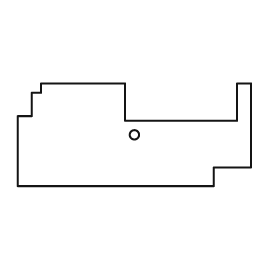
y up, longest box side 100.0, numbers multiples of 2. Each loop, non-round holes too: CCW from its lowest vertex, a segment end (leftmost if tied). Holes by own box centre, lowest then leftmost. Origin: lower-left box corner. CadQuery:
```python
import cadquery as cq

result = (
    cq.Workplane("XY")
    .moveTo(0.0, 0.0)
    .lineTo(84.0, 0.0)
    .lineTo(84.0, 8.0)
    .lineTo(100.0, 8.0)
    .lineTo(100.0, 44.0)
    .lineTo(94.0, 44.0)
    .lineTo(94.0, 28.0)
    .lineTo(46.0, 28.0)
    .lineTo(46.0, 44.0)
    .lineTo(10.0, 44.0)
    .lineTo(10.0, 40.0)
    .lineTo(6.0, 40.0)
    .lineTo(6.0, 30.0)
    .lineTo(0.0, 30.0)
    .close()
    .moveTo(50.0, 22.0)
    .circle(2.0)
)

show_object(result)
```